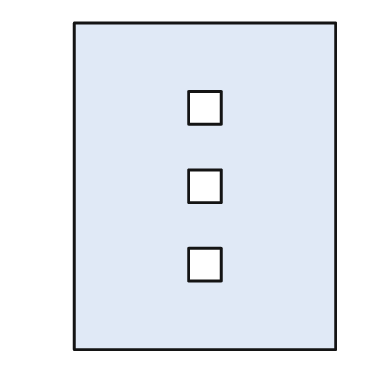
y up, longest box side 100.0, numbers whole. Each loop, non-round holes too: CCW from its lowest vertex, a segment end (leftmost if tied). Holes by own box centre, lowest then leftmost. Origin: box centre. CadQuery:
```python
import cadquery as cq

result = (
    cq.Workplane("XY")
    .moveTo(-40.0, -50.0)
    .lineTo(40.0, -50.0)
    .lineTo(40.0, 50.0)
    .lineTo(-40.0, 50.0)
    .close()
    .moveTo(-5.0, -29.0)
    .lineTo(5.0, -29.0)
    .lineTo(5.0, -19.0)
    .lineTo(-5.0, -19.0)
    .close()
    .moveTo(-5.0, -5.0)
    .lineTo(5.0, -5.0)
    .lineTo(5.0, 5.0)
    .lineTo(-5.0, 5.0)
    .close()
    .moveTo(-5.0, 19.0)
    .lineTo(5.0, 19.0)
    .lineTo(5.0, 29.0)
    .lineTo(-5.0, 29.0)
    .close()
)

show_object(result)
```